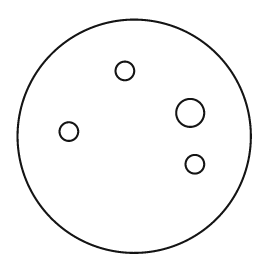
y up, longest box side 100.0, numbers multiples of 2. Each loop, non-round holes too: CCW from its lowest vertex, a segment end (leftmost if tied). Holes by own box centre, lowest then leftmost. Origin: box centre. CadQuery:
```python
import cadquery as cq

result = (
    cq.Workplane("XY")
    .moveTo(0.0, 0.0)
    .circle(50.0)
    .moveTo(26.0, -12.0)
    .circle(4.0)
    .moveTo(-28.0, 2.0)
    .circle(4.0)
    .moveTo(24.0, 10.0)
    .circle(6.0)
    .moveTo(-4.0, 28.0)
    .circle(4.0)
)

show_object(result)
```